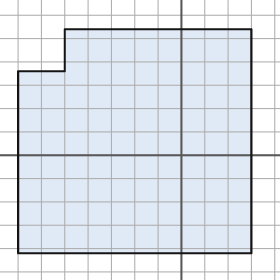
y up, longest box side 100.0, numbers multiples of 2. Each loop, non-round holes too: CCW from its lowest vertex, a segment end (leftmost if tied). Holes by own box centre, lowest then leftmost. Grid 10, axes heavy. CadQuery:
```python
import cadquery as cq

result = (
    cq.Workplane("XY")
    .moveTo(-70.0, -42.0)
    .lineTo(30.0, -42.0)
    .lineTo(30.0, 54.0)
    .lineTo(-50.0, 54.0)
    .lineTo(-50.0, 36.0)
    .lineTo(-70.0, 36.0)
    .close()
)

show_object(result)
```